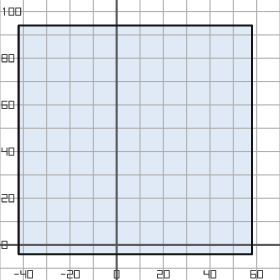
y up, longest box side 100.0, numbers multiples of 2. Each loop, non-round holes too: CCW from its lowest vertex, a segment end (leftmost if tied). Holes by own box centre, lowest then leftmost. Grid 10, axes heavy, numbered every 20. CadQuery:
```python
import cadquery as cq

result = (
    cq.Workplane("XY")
    .moveTo(-42.0, -4.0)
    .lineTo(58.0, -4.0)
    .lineTo(58.0, 94.0)
    .lineTo(-42.0, 94.0)
    .close()
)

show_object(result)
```